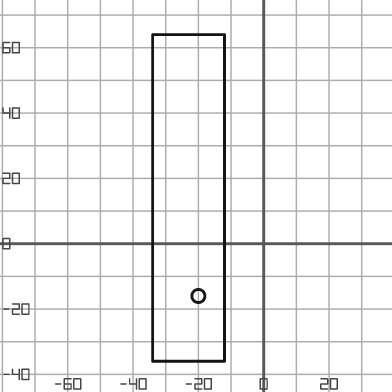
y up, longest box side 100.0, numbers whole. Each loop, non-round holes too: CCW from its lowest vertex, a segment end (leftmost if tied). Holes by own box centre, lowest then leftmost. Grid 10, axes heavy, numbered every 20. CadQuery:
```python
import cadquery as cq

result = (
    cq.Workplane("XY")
    .moveTo(-34.0, -36.0)
    .lineTo(-12.0, -36.0)
    .lineTo(-12.0, 64.0)
    .lineTo(-34.0, 64.0)
    .close()
    .moveTo(-20.0, -16.0)
    .circle(2.0)
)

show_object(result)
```